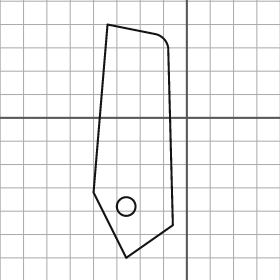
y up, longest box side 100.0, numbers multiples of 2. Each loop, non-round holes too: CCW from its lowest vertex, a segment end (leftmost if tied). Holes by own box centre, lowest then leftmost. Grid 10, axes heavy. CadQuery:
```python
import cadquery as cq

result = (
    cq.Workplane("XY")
    .moveTo(-26.0, -60.0)
    .lineTo(-6.0, -46.0)
    .lineTo(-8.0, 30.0)
    .threePointArc((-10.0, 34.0), (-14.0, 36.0))
    .lineTo(-34.0, 40.0)
    .lineTo(-40.0, -32.0)
    .close()
    .moveTo(-26.0, -38.0)
    .circle(4.0)
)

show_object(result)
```